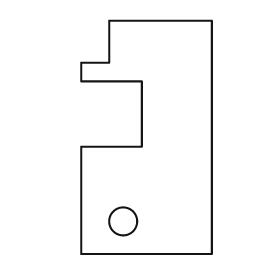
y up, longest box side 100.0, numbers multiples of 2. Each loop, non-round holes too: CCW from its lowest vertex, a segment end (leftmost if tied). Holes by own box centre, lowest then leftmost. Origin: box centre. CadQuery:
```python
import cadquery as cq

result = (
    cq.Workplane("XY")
    .moveTo(-28.0, -50.0)
    .lineTo(28.0, -50.0)
    .lineTo(28.0, 50.0)
    .lineTo(-16.0, 50.0)
    .lineTo(-16.0, 32.0)
    .lineTo(-28.0, 32.0)
    .lineTo(-28.0, 24.0)
    .lineTo(-2.0, 24.0)
    .lineTo(-2.0, -4.0)
    .lineTo(-28.0, -4.0)
    .close()
    .moveTo(-10.0, -36.0)
    .circle(6.0)
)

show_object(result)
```